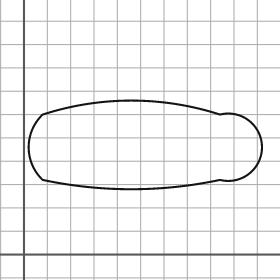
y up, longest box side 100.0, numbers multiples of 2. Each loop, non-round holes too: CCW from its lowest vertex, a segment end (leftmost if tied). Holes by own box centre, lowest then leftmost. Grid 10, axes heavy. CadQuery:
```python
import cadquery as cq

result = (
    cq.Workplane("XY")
    .moveTo(8.0, 32.0)
    .threePointArc((46.0, 28.0), (84.0, 32.0))
    .threePointArc((102.0, 46.0), (84.0, 60.0))
    .threePointArc((46.0, 66.0), (8.0, 60.0))
    .threePointArc((2.0, 46.0), (8.0, 32.0))
    .close()
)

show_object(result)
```